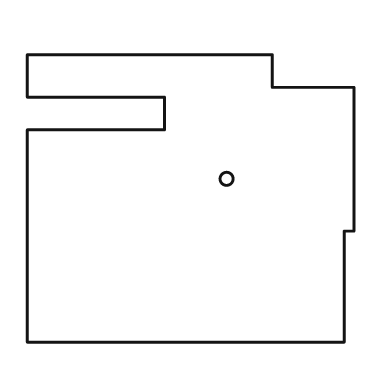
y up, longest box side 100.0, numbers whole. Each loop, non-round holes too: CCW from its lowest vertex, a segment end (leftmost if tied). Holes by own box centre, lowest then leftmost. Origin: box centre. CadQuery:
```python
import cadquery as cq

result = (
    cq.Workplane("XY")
    .moveTo(-50.0, -44.0)
    .lineTo(47.0, -44.0)
    .lineTo(47.0, -10.0)
    .lineTo(50.0, -10.0)
    .lineTo(50.0, 34.0)
    .lineTo(25.0, 34.0)
    .lineTo(25.0, 44.0)
    .lineTo(-50.0, 44.0)
    .lineTo(-50.0, 31.0)
    .lineTo(-8.0, 31.0)
    .lineTo(-8.0, 21.0)
    .lineTo(-50.0, 21.0)
    .close()
    .moveTo(11.0, 6.0)
    .circle(2.0)
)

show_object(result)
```